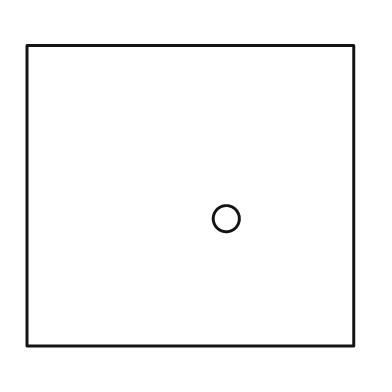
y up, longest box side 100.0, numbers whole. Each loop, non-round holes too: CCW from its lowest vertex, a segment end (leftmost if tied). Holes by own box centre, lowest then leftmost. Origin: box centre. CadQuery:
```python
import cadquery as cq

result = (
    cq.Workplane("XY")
    .moveTo(-50.0, -46.0)
    .lineTo(50.0, -46.0)
    .lineTo(50.0, 46.0)
    .lineTo(-50.0, 46.0)
    .close()
    .moveTo(11.0, -7.0)
    .circle(4.0)
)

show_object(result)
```